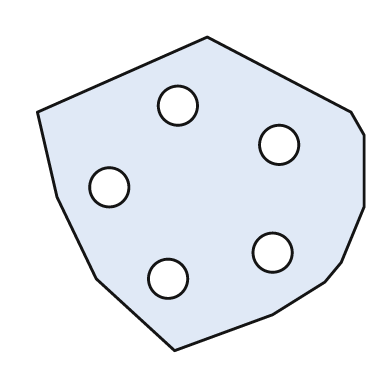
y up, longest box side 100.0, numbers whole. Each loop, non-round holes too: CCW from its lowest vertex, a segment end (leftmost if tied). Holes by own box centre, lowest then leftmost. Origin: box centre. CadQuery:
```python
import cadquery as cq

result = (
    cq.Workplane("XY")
    .moveTo(-8.0, -48.0)
    .lineTo(22.0, -37.0)
    .lineTo(38.0, -27.0)
    .lineTo(43.0, -21.0)
    .lineTo(50.0, -4.0)
    .lineTo(50.0, 18.0)
    .lineTo(46.0, 25.0)
    .lineTo(2.0, 48.0)
    .lineTo(-50.0, 25.0)
    .lineTo(-44.0, -1.0)
    .lineTo(-32.0, -26.0)
    .close()
    .moveTo(-10.0, -26.0)
    .circle(6.0)
    .moveTo(22.0, -18.0)
    .circle(6.0)
    .moveTo(-28.0, 2.0)
    .circle(6.0)
    .moveTo(24.0, 15.0)
    .circle(6.0)
    .moveTo(-7.0, 27.0)
    .circle(6.0)
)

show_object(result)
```